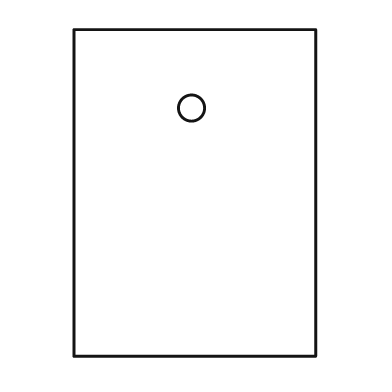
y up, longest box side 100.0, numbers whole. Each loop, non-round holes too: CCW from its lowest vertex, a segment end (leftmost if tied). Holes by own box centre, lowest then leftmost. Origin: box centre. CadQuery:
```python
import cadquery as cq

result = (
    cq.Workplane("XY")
    .moveTo(-37.0, -50.0)
    .lineTo(37.0, -50.0)
    .lineTo(37.0, 50.0)
    .lineTo(-37.0, 50.0)
    .close()
    .moveTo(-1.0, 26.0)
    .circle(4.0)
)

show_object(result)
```